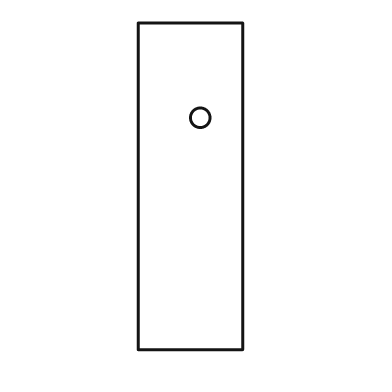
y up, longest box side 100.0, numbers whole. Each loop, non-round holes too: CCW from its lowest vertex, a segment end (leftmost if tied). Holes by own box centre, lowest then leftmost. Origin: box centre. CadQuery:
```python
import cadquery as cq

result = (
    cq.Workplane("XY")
    .moveTo(-16.0, -50.0)
    .lineTo(16.0, -50.0)
    .lineTo(16.0, 50.0)
    .lineTo(-16.0, 50.0)
    .close()
    .moveTo(3.0, 21.0)
    .circle(3.0)
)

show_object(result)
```